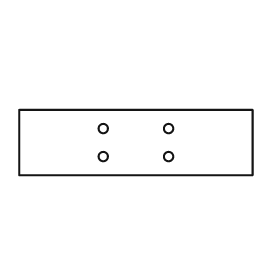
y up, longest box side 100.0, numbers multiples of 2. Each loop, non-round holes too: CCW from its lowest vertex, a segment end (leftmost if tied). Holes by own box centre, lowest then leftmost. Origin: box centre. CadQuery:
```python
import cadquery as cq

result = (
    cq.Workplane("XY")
    .moveTo(-50.0, -14.0)
    .lineTo(50.0, -14.0)
    .lineTo(50.0, 14.0)
    .lineTo(-50.0, 14.0)
    .close()
    .moveTo(-14.0, -6.0)
    .circle(2.0)
    .moveTo(14.0, -6.0)
    .circle(2.0)
    .moveTo(-14.0, 6.0)
    .circle(2.0)
    .moveTo(14.0, 6.0)
    .circle(2.0)
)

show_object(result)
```